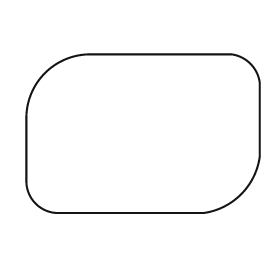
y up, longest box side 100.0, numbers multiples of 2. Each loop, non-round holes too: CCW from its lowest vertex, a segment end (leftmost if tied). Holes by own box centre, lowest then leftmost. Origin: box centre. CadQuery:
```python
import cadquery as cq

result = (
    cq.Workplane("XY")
    .moveTo(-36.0, -34.0)
    .lineTo(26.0, -34.0)
    .threePointArc((42.0, -26.0), (50.0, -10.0))
    .lineTo(50.0, 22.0)
    .threePointArc((46.0, 30.0), (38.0, 34.0))
    .lineTo(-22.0, 34.0)
    .threePointArc((-42.0, 26.0), (-50.0, 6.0))
    .lineTo(-50.0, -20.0)
    .threePointArc((-46.0, -30.0), (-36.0, -34.0))
    .close()
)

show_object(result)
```